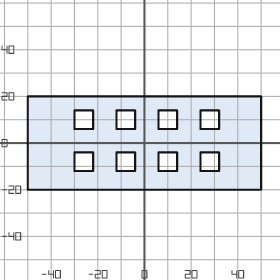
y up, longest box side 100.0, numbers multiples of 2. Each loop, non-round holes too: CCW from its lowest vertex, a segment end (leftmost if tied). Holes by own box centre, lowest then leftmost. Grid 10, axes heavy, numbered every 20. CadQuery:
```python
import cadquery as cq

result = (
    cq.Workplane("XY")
    .moveTo(-50.0, -20.0)
    .lineTo(50.0, -20.0)
    .lineTo(50.0, 20.0)
    .lineTo(-50.0, 20.0)
    .close()
    .moveTo(-30.0, -12.0)
    .lineTo(-22.0, -12.0)
    .lineTo(-22.0, -4.0)
    .lineTo(-30.0, -4.0)
    .close()
    .moveTo(-12.0, -12.0)
    .lineTo(-4.0, -12.0)
    .lineTo(-4.0, -4.0)
    .lineTo(-12.0, -4.0)
    .close()
    .moveTo(6.0, -12.0)
    .lineTo(14.0, -12.0)
    .lineTo(14.0, -4.0)
    .lineTo(6.0, -4.0)
    .close()
    .moveTo(24.0, -12.0)
    .lineTo(32.0, -12.0)
    .lineTo(32.0, -4.0)
    .lineTo(24.0, -4.0)
    .close()
    .moveTo(-30.0, 6.0)
    .lineTo(-22.0, 6.0)
    .lineTo(-22.0, 14.0)
    .lineTo(-30.0, 14.0)
    .close()
    .moveTo(-12.0, 6.0)
    .lineTo(-4.0, 6.0)
    .lineTo(-4.0, 14.0)
    .lineTo(-12.0, 14.0)
    .close()
    .moveTo(6.0, 6.0)
    .lineTo(14.0, 6.0)
    .lineTo(14.0, 14.0)
    .lineTo(6.0, 14.0)
    .close()
    .moveTo(24.0, 6.0)
    .lineTo(32.0, 6.0)
    .lineTo(32.0, 14.0)
    .lineTo(24.0, 14.0)
    .close()
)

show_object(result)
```